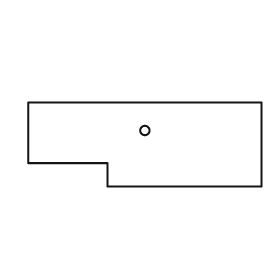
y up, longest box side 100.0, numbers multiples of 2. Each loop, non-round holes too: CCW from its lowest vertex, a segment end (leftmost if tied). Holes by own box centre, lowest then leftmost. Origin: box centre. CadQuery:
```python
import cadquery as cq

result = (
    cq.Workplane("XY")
    .moveTo(-16.0, -18.0)
    .lineTo(50.0, -18.0)
    .lineTo(50.0, 18.0)
    .lineTo(-50.0, 18.0)
    .lineTo(-50.0, -8.0)
    .lineTo(-16.0, -8.0)
    .close()
    .moveTo(0.0, 6.0)
    .circle(2.0)
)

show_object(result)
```